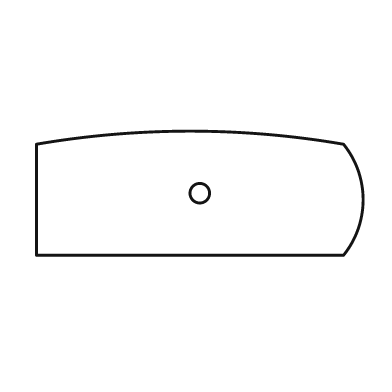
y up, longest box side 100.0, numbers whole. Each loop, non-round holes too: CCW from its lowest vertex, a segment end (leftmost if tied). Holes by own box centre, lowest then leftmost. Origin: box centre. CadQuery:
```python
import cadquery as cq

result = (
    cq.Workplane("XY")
    .moveTo(-50.0, -19.0)
    .lineTo(44.0, -19.0)
    .threePointArc((50.0, -2.0), (44.0, 15.0))
    .threePointArc((-3.0, 19.0), (-50.0, 15.0))
    .close()
    .moveTo(0.0, 0.0)
    .circle(3.0)
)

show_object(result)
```